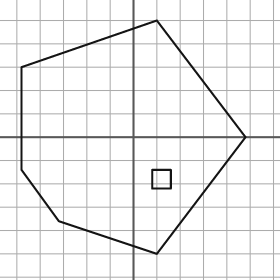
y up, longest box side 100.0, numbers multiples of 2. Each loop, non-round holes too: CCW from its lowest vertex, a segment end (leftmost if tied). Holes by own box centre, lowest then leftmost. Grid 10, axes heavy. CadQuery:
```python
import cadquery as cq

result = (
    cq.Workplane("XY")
    .moveTo(10.0, -50.0)
    .lineTo(48.0, 0.0)
    .lineTo(10.0, 50.0)
    .lineTo(-48.0, 30.0)
    .lineTo(-48.0, -14.0)
    .lineTo(-32.0, -36.0)
    .close()
    .moveTo(8.0, -22.0)
    .lineTo(16.0, -22.0)
    .lineTo(16.0, -14.0)
    .lineTo(8.0, -14.0)
    .close()
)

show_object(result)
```